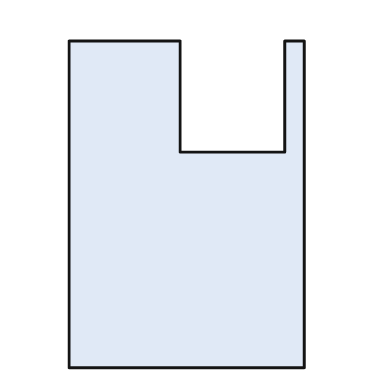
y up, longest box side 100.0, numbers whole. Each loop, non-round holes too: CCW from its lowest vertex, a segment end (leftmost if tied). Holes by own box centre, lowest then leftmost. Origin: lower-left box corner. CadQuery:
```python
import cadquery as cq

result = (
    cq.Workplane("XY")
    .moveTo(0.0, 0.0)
    .lineTo(72.0, 0.0)
    .lineTo(72.0, 100.0)
    .lineTo(66.0, 100.0)
    .lineTo(66.0, 66.0)
    .lineTo(34.0, 66.0)
    .lineTo(34.0, 100.0)
    .lineTo(0.0, 100.0)
    .close()
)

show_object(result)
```